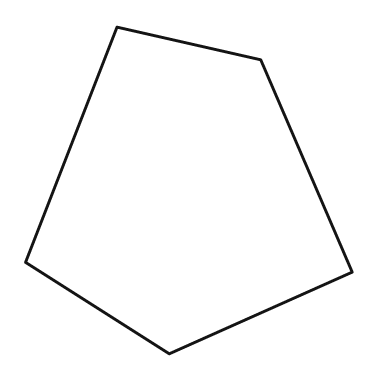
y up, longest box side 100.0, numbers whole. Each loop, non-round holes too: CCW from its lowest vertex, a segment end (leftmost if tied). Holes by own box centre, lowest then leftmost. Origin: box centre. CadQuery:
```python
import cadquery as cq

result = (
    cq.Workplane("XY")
    .moveTo(-6.0, -50.0)
    .lineTo(50.0, -25.0)
    .lineTo(22.0, 40.0)
    .lineTo(-22.0, 50.0)
    .lineTo(-50.0, -22.0)
    .close()
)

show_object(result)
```